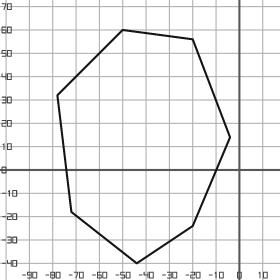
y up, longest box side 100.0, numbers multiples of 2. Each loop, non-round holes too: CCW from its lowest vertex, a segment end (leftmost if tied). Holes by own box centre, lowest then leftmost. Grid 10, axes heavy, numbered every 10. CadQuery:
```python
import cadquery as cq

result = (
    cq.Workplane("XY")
    .moveTo(-44.0, -40.0)
    .lineTo(-20.0, -24.0)
    .lineTo(-4.0, 14.0)
    .lineTo(-20.0, 56.0)
    .lineTo(-50.0, 60.0)
    .lineTo(-78.0, 32.0)
    .lineTo(-72.0, -18.0)
    .close()
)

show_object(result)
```